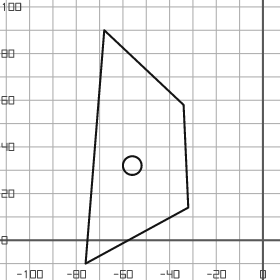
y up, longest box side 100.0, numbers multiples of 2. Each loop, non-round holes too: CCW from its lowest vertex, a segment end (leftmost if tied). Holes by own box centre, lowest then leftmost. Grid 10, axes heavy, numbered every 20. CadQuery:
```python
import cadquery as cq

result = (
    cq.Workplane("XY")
    .moveTo(-76.0, -10.0)
    .lineTo(-32.0, 14.0)
    .lineTo(-34.0, 58.0)
    .lineTo(-68.0, 90.0)
    .close()
    .moveTo(-56.0, 32.0)
    .circle(4.0)
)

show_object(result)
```